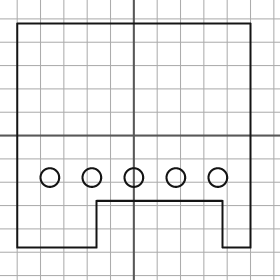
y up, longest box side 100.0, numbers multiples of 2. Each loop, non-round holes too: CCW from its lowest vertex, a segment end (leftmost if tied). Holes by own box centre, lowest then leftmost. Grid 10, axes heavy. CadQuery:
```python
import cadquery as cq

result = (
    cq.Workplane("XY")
    .moveTo(-50.0, -48.0)
    .lineTo(-16.0, -48.0)
    .lineTo(-16.0, -28.0)
    .lineTo(38.0, -28.0)
    .lineTo(38.0, -48.0)
    .lineTo(50.0, -48.0)
    .lineTo(50.0, 48.0)
    .lineTo(-50.0, 48.0)
    .close()
    .moveTo(-36.0, -18.0)
    .circle(4.0)
    .moveTo(-18.0, -18.0)
    .circle(4.0)
    .moveTo(0.0, -18.0)
    .circle(4.0)
    .moveTo(18.0, -18.0)
    .circle(4.0)
    .moveTo(36.0, -18.0)
    .circle(4.0)
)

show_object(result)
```